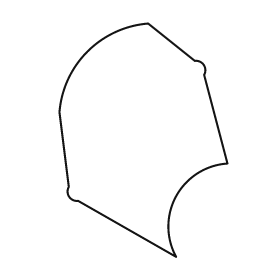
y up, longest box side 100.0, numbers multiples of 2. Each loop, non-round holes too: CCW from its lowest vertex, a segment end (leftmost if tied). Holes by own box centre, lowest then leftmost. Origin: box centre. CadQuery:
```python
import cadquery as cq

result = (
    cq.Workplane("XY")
    .moveTo(14.0, -50.0)
    .threePointArc((14.0, -24.0), (36.0, -10.0))
    .lineTo(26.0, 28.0)
    .threePointArc((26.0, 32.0), (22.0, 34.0))
    .lineTo(2.0, 50.0)
    .threePointArc((-24.0, 38.0), (-36.0, 12.0))
    .lineTo(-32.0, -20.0)
    .threePointArc((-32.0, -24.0), (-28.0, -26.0))
    .close()
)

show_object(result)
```